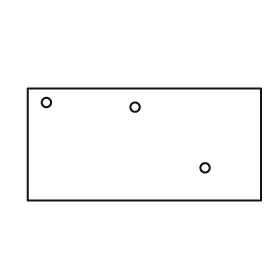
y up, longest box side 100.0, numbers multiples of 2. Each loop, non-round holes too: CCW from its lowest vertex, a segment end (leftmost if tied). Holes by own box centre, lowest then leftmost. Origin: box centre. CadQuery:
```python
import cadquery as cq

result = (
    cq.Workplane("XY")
    .moveTo(-50.0, -24.0)
    .lineTo(50.0, -24.0)
    .lineTo(50.0, 24.0)
    .lineTo(-50.0, 24.0)
    .close()
    .moveTo(26.0, -10.0)
    .circle(2.0)
    .moveTo(-4.0, 16.0)
    .circle(2.0)
    .moveTo(-42.0, 18.0)
    .circle(2.0)
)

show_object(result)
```